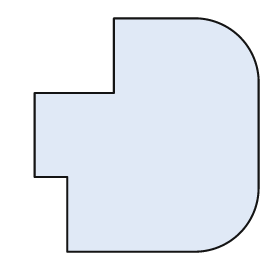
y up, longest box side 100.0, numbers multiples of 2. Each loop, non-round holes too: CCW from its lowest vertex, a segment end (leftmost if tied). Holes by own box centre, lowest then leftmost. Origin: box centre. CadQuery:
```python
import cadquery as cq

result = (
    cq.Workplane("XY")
    .moveTo(-34.0, -50.0)
    .lineTo(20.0, -50.0)
    .threePointArc((40.0, -42.0), (48.0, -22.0))
    .lineTo(48.0, 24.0)
    .threePointArc((40.0, 42.0), (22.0, 50.0))
    .lineTo(-14.0, 50.0)
    .lineTo(-14.0, 18.0)
    .lineTo(-48.0, 18.0)
    .lineTo(-48.0, -18.0)
    .lineTo(-34.0, -18.0)
    .close()
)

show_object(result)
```